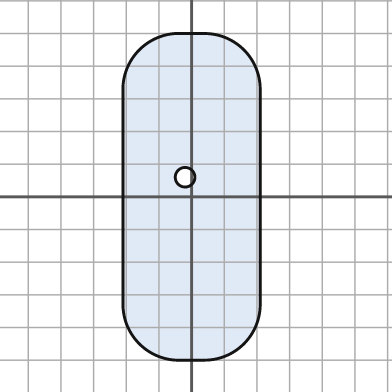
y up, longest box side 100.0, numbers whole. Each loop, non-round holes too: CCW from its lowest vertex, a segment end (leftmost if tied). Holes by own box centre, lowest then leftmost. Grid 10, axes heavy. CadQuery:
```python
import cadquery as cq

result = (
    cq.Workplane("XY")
    .moveTo(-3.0, -50.0)
    .lineTo(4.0, -50.0)
    .threePointArc((16.0, -45.0), (21.0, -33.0))
    .lineTo(21.0, 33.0)
    .threePointArc((16.0, 45.0), (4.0, 50.0))
    .lineTo(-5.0, 50.0)
    .threePointArc((-16.0, 45.0), (-21.0, 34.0))
    .lineTo(-21.0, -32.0)
    .threePointArc((-16.0, -45.0), (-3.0, -50.0))
    .close()
    .moveTo(-2.0, 6.0)
    .circle(3.0)
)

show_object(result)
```